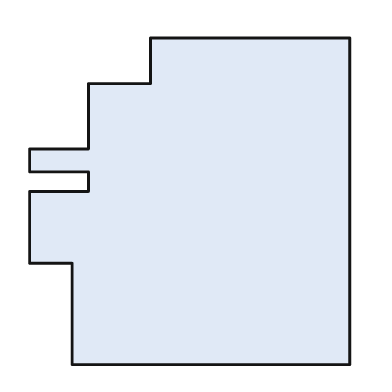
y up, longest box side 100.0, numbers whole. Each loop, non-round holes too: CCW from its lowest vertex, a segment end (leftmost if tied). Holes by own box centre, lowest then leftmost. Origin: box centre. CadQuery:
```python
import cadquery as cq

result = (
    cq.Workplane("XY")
    .moveTo(-36.0, -50.0)
    .lineTo(49.0, -50.0)
    .lineTo(49.0, 50.0)
    .lineTo(-12.0, 50.0)
    .lineTo(-12.0, 36.0)
    .lineTo(-31.0, 36.0)
    .lineTo(-31.0, 16.0)
    .lineTo(-49.0, 16.0)
    .lineTo(-49.0, 9.0)
    .lineTo(-31.0, 9.0)
    .lineTo(-31.0, 3.0)
    .lineTo(-49.0, 3.0)
    .lineTo(-49.0, -19.0)
    .lineTo(-36.0, -19.0)
    .close()
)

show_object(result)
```